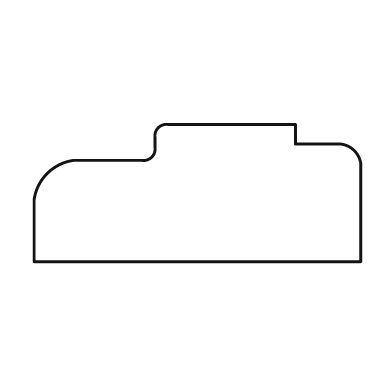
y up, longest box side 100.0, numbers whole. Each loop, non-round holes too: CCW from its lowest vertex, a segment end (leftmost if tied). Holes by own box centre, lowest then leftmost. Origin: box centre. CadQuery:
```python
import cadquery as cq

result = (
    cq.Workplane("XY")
    .moveTo(-50.0, -21.0)
    .lineTo(50.0, -21.0)
    .lineTo(50.0, 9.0)
    .threePointArc((48.0, 13.0), (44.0, 15.0))
    .lineTo(30.0, 15.0)
    .lineTo(30.0, 21.0)
    .lineTo(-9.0, 21.0)
    .threePointArc((-12.0, 20.0), (-13.0, 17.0))
    .lineTo(-13.0, 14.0)
    .threePointArc((-14.0, 11.0), (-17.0, 10.0))
    .lineTo(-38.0, 10.0)
    .threePointArc((-46.0, 6.0), (-50.0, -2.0))
    .close()
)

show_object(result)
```